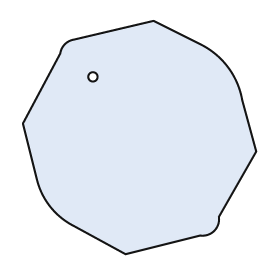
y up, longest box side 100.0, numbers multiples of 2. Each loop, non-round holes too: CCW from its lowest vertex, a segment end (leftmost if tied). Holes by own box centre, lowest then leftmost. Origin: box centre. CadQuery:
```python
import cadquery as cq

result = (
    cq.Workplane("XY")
    .moveTo(-6.0, -50.0)
    .lineTo(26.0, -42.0)
    .threePointArc((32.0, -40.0), (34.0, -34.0))
    .lineTo(50.0, -6.0)
    .lineTo(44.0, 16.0)
    .threePointArc((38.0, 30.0), (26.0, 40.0))
    .lineTo(6.0, 50.0)
    .lineTo(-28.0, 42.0)
    .threePointArc((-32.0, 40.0), (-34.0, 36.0))
    .lineTo(-50.0, 6.0)
    .lineTo(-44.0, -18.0)
    .threePointArc((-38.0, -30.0), (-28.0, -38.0))
    .close()
    .moveTo(-20.0, 26.0)
    .circle(2.0)
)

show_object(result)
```